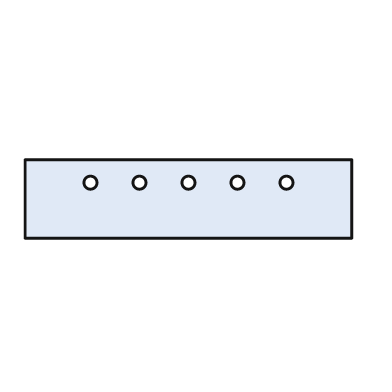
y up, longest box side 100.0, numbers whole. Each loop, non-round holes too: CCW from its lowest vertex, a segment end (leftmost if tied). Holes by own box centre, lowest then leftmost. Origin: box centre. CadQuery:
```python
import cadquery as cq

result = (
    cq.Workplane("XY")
    .moveTo(-50.0, -12.0)
    .lineTo(50.0, -12.0)
    .lineTo(50.0, 12.0)
    .lineTo(-50.0, 12.0)
    .close()
    .moveTo(-30.0, 5.0)
    .circle(2.0)
    .moveTo(-15.0, 5.0)
    .circle(2.0)
    .moveTo(0.0, 5.0)
    .circle(2.0)
    .moveTo(15.0, 5.0)
    .circle(2.0)
    .moveTo(30.0, 5.0)
    .circle(2.0)
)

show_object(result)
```